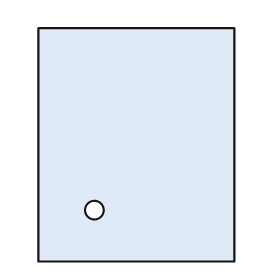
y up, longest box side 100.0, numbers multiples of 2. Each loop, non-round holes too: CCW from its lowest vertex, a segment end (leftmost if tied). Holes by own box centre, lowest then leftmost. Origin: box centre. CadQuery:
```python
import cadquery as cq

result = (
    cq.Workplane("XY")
    .moveTo(-42.0, -50.0)
    .lineTo(42.0, -50.0)
    .lineTo(42.0, 50.0)
    .lineTo(-42.0, 50.0)
    .close()
    .moveTo(-18.0, -28.0)
    .circle(4.0)
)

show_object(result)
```